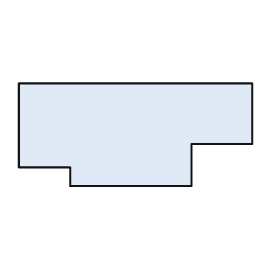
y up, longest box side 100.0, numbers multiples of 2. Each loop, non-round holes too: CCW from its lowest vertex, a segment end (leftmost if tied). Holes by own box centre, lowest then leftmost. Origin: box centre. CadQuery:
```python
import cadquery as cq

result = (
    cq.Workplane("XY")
    .moveTo(-28.0, -22.0)
    .lineTo(24.0, -22.0)
    .lineTo(24.0, -4.0)
    .lineTo(50.0, -4.0)
    .lineTo(50.0, 22.0)
    .lineTo(-50.0, 22.0)
    .lineTo(-50.0, -14.0)
    .lineTo(-28.0, -14.0)
    .close()
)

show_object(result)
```